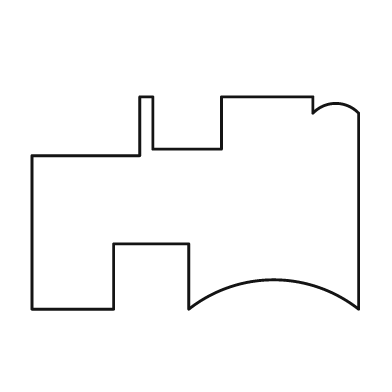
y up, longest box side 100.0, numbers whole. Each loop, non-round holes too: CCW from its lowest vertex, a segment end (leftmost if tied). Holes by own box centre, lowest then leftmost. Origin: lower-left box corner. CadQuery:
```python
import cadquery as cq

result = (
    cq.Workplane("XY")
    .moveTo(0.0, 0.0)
    .lineTo(25.0, 0.0)
    .lineTo(25.0, 20.0)
    .lineTo(48.0, 20.0)
    .lineTo(48.0, 0.0)
    .threePointArc((74.0, 9.0), (100.0, 0.0))
    .lineTo(100.0, 60.0)
    .threePointArc((93.0, 63.0), (86.0, 60.0))
    .lineTo(86.0, 65.0)
    .lineTo(58.0, 65.0)
    .lineTo(58.0, 49.0)
    .lineTo(37.0, 49.0)
    .lineTo(37.0, 65.0)
    .lineTo(33.0, 65.0)
    .lineTo(33.0, 47.0)
    .lineTo(0.0, 47.0)
    .close()
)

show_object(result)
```